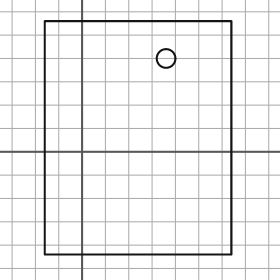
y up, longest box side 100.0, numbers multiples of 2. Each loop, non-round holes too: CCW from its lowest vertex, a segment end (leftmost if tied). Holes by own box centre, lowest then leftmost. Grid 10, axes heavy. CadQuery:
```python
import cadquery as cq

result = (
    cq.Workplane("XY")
    .moveTo(-16.0, -44.0)
    .lineTo(64.0, -44.0)
    .lineTo(64.0, 56.0)
    .lineTo(-16.0, 56.0)
    .close()
    .moveTo(36.0, 40.0)
    .circle(4.0)
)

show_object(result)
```